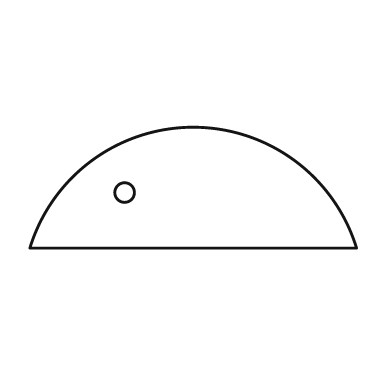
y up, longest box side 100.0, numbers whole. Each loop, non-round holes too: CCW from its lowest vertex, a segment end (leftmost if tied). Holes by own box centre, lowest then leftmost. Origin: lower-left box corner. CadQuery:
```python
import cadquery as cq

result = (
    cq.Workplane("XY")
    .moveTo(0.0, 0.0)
    .lineTo(100.0, 0.0)
    .threePointArc((50.0, 37.0), (0.0, 0.0))
    .close()
    .moveTo(29.0, 17.0)
    .circle(3.0)
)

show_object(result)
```